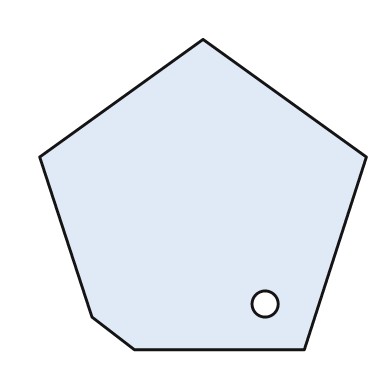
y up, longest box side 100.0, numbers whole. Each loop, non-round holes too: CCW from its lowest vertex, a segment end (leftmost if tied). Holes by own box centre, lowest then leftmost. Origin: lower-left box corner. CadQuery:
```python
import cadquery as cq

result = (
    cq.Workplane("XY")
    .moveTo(29.0, 0.0)
    .lineTo(81.0, 0.0)
    .lineTo(100.0, 59.0)
    .lineTo(50.0, 95.0)
    .lineTo(0.0, 59.0)
    .lineTo(16.0, 10.0)
    .close()
    .moveTo(69.0, 14.0)
    .circle(4.0)
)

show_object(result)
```